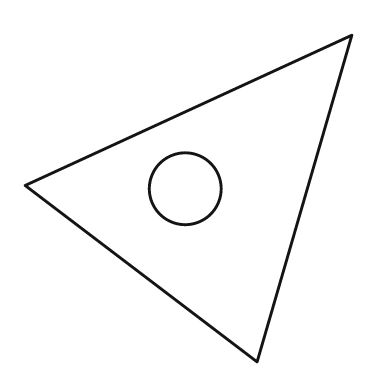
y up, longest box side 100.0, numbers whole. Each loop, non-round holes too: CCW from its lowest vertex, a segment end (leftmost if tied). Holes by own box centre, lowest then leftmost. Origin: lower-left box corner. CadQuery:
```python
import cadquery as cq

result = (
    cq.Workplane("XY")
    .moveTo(71.0, 0.0)
    .lineTo(100.0, 100.0)
    .lineTo(0.0, 54.0)
    .close()
    .moveTo(49.0, 53.0)
    .circle(11.0)
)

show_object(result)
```